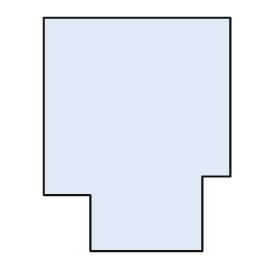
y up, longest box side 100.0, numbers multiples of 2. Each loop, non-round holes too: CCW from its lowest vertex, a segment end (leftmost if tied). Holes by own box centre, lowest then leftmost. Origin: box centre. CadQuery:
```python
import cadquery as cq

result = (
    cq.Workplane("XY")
    .moveTo(-20.0, -50.0)
    .lineTo(28.0, -50.0)
    .lineTo(28.0, -18.0)
    .lineTo(40.0, -18.0)
    .lineTo(40.0, 50.0)
    .lineTo(-40.0, 50.0)
    .lineTo(-40.0, -26.0)
    .lineTo(-20.0, -26.0)
    .close()
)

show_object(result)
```